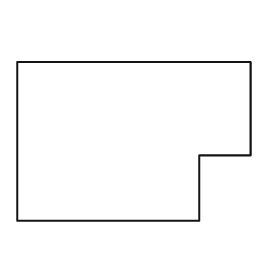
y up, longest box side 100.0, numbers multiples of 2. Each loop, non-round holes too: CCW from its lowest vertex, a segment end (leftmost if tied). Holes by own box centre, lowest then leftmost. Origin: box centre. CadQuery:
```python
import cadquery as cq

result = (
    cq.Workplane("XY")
    .moveTo(-50.0, -34.0)
    .lineTo(28.0, -34.0)
    .lineTo(28.0, -6.0)
    .lineTo(50.0, -6.0)
    .lineTo(50.0, 34.0)
    .lineTo(-50.0, 34.0)
    .close()
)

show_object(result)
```